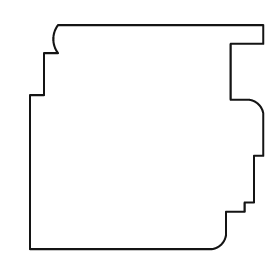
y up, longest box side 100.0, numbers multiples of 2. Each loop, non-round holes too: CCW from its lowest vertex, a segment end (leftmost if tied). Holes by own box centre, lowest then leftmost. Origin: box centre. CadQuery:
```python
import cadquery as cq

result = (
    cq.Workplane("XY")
    .moveTo(-50.0, -48.0)
    .lineTo(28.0, -48.0)
    .threePointArc((32.0, -46.0), (34.0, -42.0))
    .lineTo(34.0, -32.0)
    .lineTo(42.0, -32.0)
    .lineTo(42.0, -28.0)
    .lineTo(46.0, -28.0)
    .lineTo(46.0, -8.0)
    .lineTo(50.0, -8.0)
    .lineTo(50.0, 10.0)
    .threePointArc((48.0, 14.0), (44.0, 16.0))
    .lineTo(36.0, 16.0)
    .lineTo(36.0, 40.0)
    .lineTo(50.0, 40.0)
    .lineTo(50.0, 48.0)
    .lineTo(-38.0, 48.0)
    .threePointArc((-40.0, 42.0), (-38.0, 36.0))
    .lineTo(-44.0, 36.0)
    .lineTo(-44.0, 18.0)
    .lineTo(-50.0, 18.0)
    .close()
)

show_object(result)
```